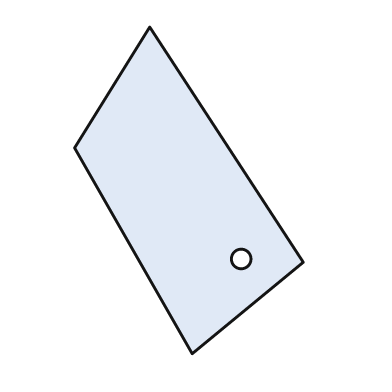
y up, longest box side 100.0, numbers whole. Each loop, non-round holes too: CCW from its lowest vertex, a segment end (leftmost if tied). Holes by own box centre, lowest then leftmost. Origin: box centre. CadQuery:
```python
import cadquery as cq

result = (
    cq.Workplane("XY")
    .moveTo(1.0, -50.0)
    .lineTo(35.0, -22.0)
    .lineTo(-12.0, 50.0)
    .lineTo(-35.0, 13.0)
    .close()
    .moveTo(16.0, -21.0)
    .circle(3.0)
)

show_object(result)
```